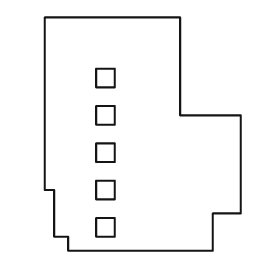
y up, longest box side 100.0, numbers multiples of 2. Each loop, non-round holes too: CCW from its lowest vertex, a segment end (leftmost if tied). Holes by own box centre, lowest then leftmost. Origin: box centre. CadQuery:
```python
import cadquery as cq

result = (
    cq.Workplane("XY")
    .moveTo(-32.0, -50.0)
    .lineTo(30.0, -50.0)
    .lineTo(30.0, -34.0)
    .lineTo(42.0, -34.0)
    .lineTo(42.0, 8.0)
    .lineTo(16.0, 8.0)
    .lineTo(16.0, 50.0)
    .lineTo(-42.0, 50.0)
    .lineTo(-42.0, -24.0)
    .lineTo(-38.0, -24.0)
    .lineTo(-38.0, -44.0)
    .lineTo(-32.0, -44.0)
    .close()
    .moveTo(-20.0, -44.0)
    .lineTo(-12.0, -44.0)
    .lineTo(-12.0, -36.0)
    .lineTo(-20.0, -36.0)
    .close()
    .moveTo(-20.0, -28.0)
    .lineTo(-12.0, -28.0)
    .lineTo(-12.0, -20.0)
    .lineTo(-20.0, -20.0)
    .close()
    .moveTo(-20.0, -12.0)
    .lineTo(-12.0, -12.0)
    .lineTo(-12.0, -4.0)
    .lineTo(-20.0, -4.0)
    .close()
    .moveTo(-20.0, 4.0)
    .lineTo(-12.0, 4.0)
    .lineTo(-12.0, 12.0)
    .lineTo(-20.0, 12.0)
    .close()
    .moveTo(-20.0, 20.0)
    .lineTo(-12.0, 20.0)
    .lineTo(-12.0, 28.0)
    .lineTo(-20.0, 28.0)
    .close()
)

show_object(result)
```